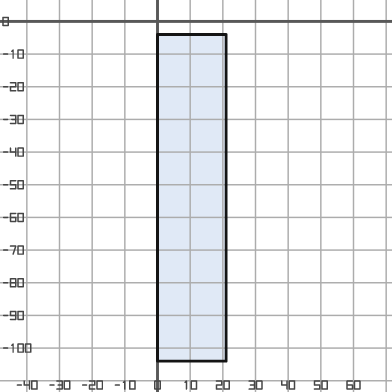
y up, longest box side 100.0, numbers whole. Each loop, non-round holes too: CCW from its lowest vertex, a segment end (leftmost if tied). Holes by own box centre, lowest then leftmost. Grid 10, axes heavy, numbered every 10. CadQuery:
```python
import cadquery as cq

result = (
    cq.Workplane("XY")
    .moveTo(0.0, -104.0)
    .lineTo(21.0, -104.0)
    .lineTo(21.0, -4.0)
    .lineTo(0.0, -4.0)
    .close()
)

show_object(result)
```